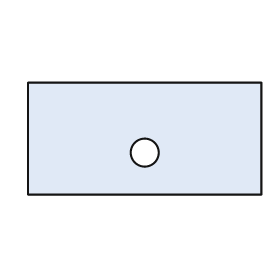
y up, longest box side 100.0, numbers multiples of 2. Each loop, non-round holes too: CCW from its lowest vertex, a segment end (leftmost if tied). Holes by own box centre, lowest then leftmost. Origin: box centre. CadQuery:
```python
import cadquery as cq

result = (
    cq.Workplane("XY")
    .moveTo(-50.0, -24.0)
    .lineTo(50.0, -24.0)
    .lineTo(50.0, 24.0)
    .lineTo(-50.0, 24.0)
    .close()
    .moveTo(0.0, -6.0)
    .circle(6.0)
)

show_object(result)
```